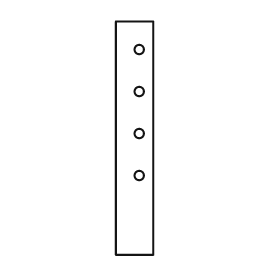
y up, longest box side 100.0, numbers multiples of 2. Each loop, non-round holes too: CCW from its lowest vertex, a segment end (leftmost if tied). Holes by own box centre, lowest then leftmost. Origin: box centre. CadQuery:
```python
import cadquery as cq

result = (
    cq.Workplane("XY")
    .moveTo(-8.0, -50.0)
    .lineTo(8.0, -50.0)
    .lineTo(8.0, 50.0)
    .lineTo(-8.0, 50.0)
    .close()
    .moveTo(2.0, -16.0)
    .circle(2.0)
    .moveTo(2.0, 2.0)
    .circle(2.0)
    .moveTo(2.0, 20.0)
    .circle(2.0)
    .moveTo(2.0, 38.0)
    .circle(2.0)
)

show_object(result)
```